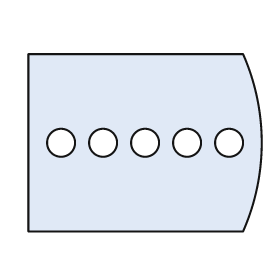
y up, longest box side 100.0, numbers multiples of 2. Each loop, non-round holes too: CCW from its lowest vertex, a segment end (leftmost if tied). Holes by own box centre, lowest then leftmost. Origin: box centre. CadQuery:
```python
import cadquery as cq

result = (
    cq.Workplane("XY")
    .moveTo(-50.0, -38.0)
    .lineTo(42.0, -38.0)
    .threePointArc((50.0, 0.0), (42.0, 38.0))
    .lineTo(-50.0, 38.0)
    .close()
    .moveTo(-36.0, 0.0)
    .circle(6.0)
    .moveTo(-18.0, 0.0)
    .circle(6.0)
    .moveTo(0.0, 0.0)
    .circle(6.0)
    .moveTo(18.0, 0.0)
    .circle(6.0)
    .moveTo(36.0, 0.0)
    .circle(6.0)
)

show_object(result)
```